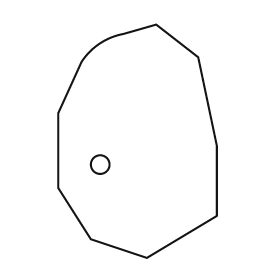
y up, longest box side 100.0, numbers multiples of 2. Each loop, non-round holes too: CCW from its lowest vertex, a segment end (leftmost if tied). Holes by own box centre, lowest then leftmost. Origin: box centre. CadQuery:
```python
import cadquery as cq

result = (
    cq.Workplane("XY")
    .moveTo(4.0, -50.0)
    .lineTo(34.0, -32.0)
    .lineTo(34.0, -2.0)
    .lineTo(26.0, 36.0)
    .lineTo(8.0, 50.0)
    .lineTo(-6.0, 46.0)
    .threePointArc((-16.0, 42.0), (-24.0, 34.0))
    .lineTo(-34.0, 12.0)
    .lineTo(-34.0, -20.0)
    .lineTo(-20.0, -42.0)
    .close()
    .moveTo(-16.0, -10.0)
    .circle(4.0)
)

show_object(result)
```